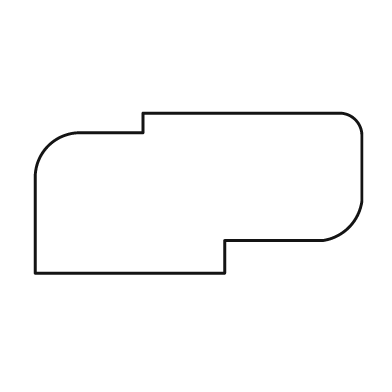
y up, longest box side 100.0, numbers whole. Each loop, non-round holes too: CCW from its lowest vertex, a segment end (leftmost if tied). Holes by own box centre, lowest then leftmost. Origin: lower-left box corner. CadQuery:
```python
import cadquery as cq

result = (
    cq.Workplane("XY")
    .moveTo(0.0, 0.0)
    .lineTo(58.0, 0.0)
    .lineTo(58.0, 10.0)
    .lineTo(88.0, 10.0)
    .threePointArc((96.0, 14.0), (100.0, 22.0))
    .lineTo(100.0, 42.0)
    .threePointArc((98.0, 47.0), (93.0, 49.0))
    .lineTo(33.0, 49.0)
    .lineTo(33.0, 43.0)
    .lineTo(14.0, 43.0)
    .threePointArc((4.0, 39.0), (0.0, 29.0))
    .close()
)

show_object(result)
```